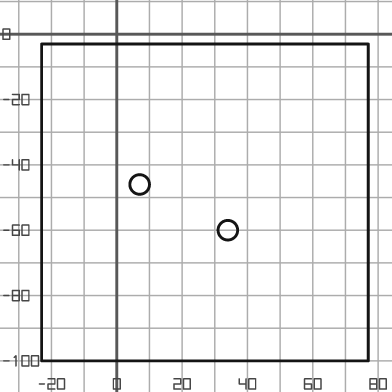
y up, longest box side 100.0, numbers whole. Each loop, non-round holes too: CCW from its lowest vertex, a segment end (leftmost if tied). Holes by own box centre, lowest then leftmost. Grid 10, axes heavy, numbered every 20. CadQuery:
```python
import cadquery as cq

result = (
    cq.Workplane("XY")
    .moveTo(-23.0, -100.0)
    .lineTo(77.0, -100.0)
    .lineTo(77.0, -3.0)
    .lineTo(-23.0, -3.0)
    .close()
    .moveTo(34.0, -60.0)
    .circle(3.0)
    .moveTo(7.0, -46.0)
    .circle(3.0)
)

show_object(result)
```